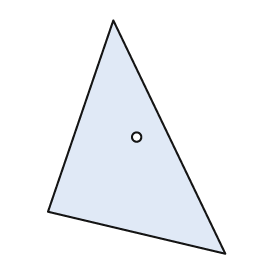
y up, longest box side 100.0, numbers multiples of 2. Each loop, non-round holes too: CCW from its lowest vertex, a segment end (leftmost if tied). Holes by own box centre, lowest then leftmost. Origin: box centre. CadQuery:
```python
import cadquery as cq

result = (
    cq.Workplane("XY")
    .moveTo(38.0, -50.0)
    .lineTo(-10.0, 50.0)
    .lineTo(-38.0, -32.0)
    .close()
    .moveTo(0.0, 0.0)
    .circle(2.0)
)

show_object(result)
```